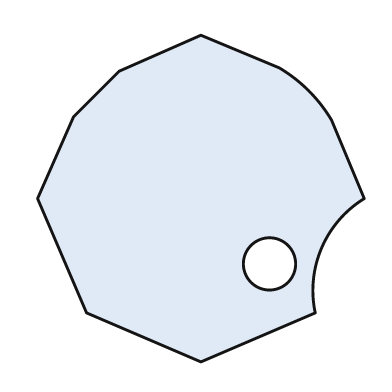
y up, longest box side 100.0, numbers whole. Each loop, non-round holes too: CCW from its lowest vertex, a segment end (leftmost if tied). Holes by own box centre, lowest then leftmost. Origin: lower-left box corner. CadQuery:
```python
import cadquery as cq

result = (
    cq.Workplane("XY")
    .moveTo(50.0, 0.0)
    .lineTo(85.0, 15.0)
    .threePointArc((87.0, 35.0), (100.0, 50.0))
    .lineTo(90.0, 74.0)
    .threePointArc((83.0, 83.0), (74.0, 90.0))
    .lineTo(50.0, 100.0)
    .lineTo(25.0, 89.0)
    .lineTo(11.0, 75.0)
    .lineTo(0.0, 50.0)
    .lineTo(15.0, 15.0)
    .close()
    .moveTo(71.0, 30.0)
    .circle(8.0)
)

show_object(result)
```